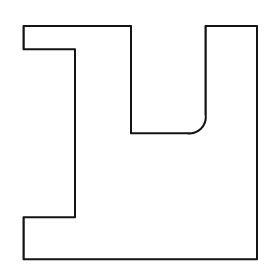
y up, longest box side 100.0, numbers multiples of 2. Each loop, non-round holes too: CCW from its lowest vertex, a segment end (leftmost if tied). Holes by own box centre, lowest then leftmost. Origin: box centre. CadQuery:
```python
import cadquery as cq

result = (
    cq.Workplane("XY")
    .moveTo(-50.0, -50.0)
    .lineTo(50.0, -50.0)
    .lineTo(50.0, 50.0)
    .lineTo(28.0, 50.0)
    .lineTo(28.0, 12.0)
    .threePointArc((26.0, 6.0), (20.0, 4.0))
    .lineTo(-4.0, 4.0)
    .lineTo(-4.0, 50.0)
    .lineTo(-50.0, 50.0)
    .lineTo(-50.0, 40.0)
    .lineTo(-28.0, 40.0)
    .lineTo(-28.0, -32.0)
    .lineTo(-50.0, -32.0)
    .close()
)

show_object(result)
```